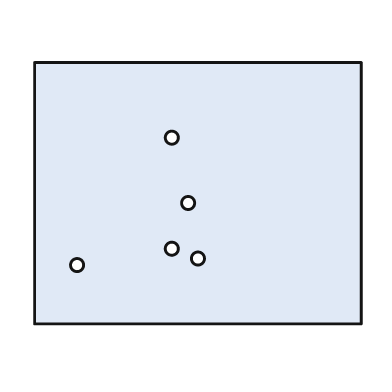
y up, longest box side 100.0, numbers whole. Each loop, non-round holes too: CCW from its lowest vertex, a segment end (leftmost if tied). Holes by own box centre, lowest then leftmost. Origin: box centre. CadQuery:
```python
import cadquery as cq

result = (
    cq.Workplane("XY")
    .moveTo(-50.0, -40.0)
    .lineTo(50.0, -40.0)
    .lineTo(50.0, 40.0)
    .lineTo(-50.0, 40.0)
    .close()
    .moveTo(-37.0, -22.0)
    .circle(2.0)
    .moveTo(0.0, -20.0)
    .circle(2.0)
    .moveTo(-8.0, -17.0)
    .circle(2.0)
    .moveTo(-3.0, -3.0)
    .circle(2.0)
    .moveTo(-8.0, 17.0)
    .circle(2.0)
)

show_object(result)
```